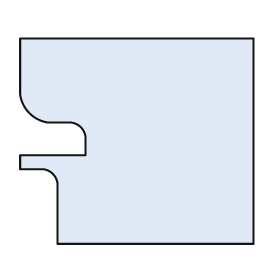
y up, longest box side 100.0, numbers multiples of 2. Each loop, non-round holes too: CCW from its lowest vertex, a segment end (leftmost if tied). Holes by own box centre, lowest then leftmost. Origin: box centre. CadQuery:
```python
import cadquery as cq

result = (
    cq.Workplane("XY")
    .moveTo(-34.0, -44.0)
    .lineTo(50.0, -44.0)
    .lineTo(50.0, 44.0)
    .lineTo(-50.0, 44.0)
    .lineTo(-50.0, 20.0)
    .threePointArc((-46.0, 12.0), (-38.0, 8.0))
    .lineTo(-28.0, 8.0)
    .threePointArc((-24.0, 6.0), (-22.0, 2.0))
    .lineTo(-22.0, -6.0)
    .lineTo(-50.0, -6.0)
    .lineTo(-50.0, -12.0)
    .lineTo(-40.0, -12.0)
    .threePointArc((-36.0, -14.0), (-34.0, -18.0))
    .close()
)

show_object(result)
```